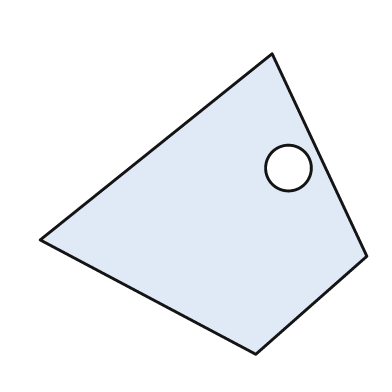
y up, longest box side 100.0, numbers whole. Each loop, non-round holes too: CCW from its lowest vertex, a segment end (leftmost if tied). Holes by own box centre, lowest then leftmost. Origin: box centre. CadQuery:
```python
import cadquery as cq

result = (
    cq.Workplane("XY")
    .moveTo(16.0, -46.0)
    .lineTo(50.0, -16.0)
    .lineTo(21.0, 46.0)
    .lineTo(-50.0, -11.0)
    .close()
    .moveTo(26.0, 11.0)
    .circle(7.0)
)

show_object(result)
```